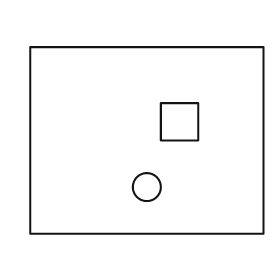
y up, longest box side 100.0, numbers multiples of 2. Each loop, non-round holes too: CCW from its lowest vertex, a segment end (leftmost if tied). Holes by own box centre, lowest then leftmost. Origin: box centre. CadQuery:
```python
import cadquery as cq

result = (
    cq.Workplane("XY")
    .moveTo(-50.0, -40.0)
    .lineTo(50.0, -40.0)
    .lineTo(50.0, 40.0)
    .lineTo(-50.0, 40.0)
    .close()
    .moveTo(0.0, -20.0)
    .circle(6.0)
    .moveTo(6.0, 0.0)
    .lineTo(22.0, 0.0)
    .lineTo(22.0, 16.0)
    .lineTo(6.0, 16.0)
    .close()
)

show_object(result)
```